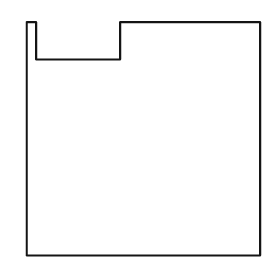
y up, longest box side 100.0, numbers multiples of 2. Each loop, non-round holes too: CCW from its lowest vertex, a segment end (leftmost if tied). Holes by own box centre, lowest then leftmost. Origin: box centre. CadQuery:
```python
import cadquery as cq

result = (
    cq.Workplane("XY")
    .moveTo(-50.0, -50.0)
    .lineTo(50.0, -50.0)
    .lineTo(50.0, 50.0)
    .lineTo(-10.0, 50.0)
    .lineTo(-10.0, 34.0)
    .lineTo(-46.0, 34.0)
    .lineTo(-46.0, 50.0)
    .lineTo(-50.0, 50.0)
    .close()
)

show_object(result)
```